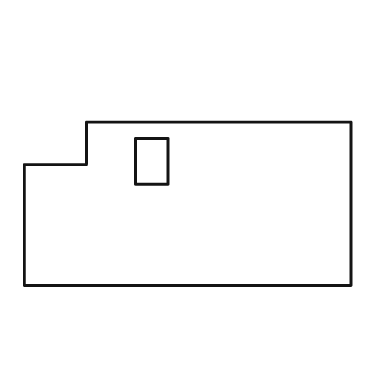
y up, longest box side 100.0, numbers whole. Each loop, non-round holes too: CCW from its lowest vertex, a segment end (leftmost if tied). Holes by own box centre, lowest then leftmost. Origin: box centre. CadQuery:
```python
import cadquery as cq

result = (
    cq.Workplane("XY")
    .moveTo(-50.0, -25.0)
    .lineTo(50.0, -25.0)
    .lineTo(50.0, 25.0)
    .lineTo(-31.0, 25.0)
    .lineTo(-31.0, 12.0)
    .lineTo(-50.0, 12.0)
    .close()
    .moveTo(-16.0, 6.0)
    .lineTo(-6.0, 6.0)
    .lineTo(-6.0, 20.0)
    .lineTo(-16.0, 20.0)
    .close()
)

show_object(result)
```